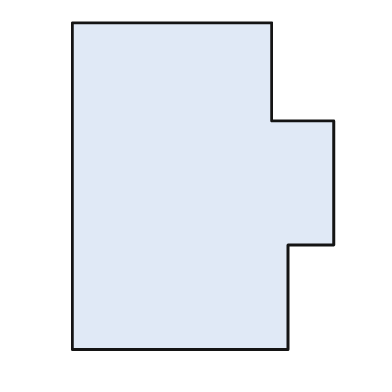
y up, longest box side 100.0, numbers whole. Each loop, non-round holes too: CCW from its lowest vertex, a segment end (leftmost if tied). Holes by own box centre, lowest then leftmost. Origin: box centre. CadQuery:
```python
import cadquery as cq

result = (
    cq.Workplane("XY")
    .moveTo(-40.0, -50.0)
    .lineTo(26.0, -50.0)
    .lineTo(26.0, -18.0)
    .lineTo(40.0, -18.0)
    .lineTo(40.0, 20.0)
    .lineTo(21.0, 20.0)
    .lineTo(21.0, 50.0)
    .lineTo(-40.0, 50.0)
    .close()
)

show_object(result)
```